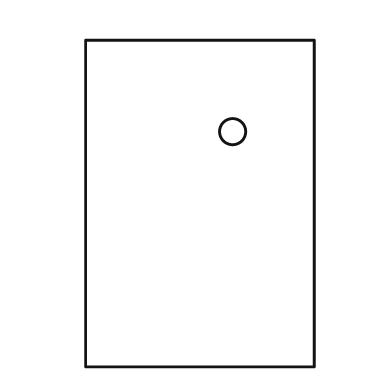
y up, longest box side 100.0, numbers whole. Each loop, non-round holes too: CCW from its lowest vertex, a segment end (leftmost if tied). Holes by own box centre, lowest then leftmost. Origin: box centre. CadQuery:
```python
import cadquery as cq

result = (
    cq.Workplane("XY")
    .moveTo(-35.0, -50.0)
    .lineTo(35.0, -50.0)
    .lineTo(35.0, 50.0)
    .lineTo(-35.0, 50.0)
    .close()
    .moveTo(10.0, 22.0)
    .circle(4.0)
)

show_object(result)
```